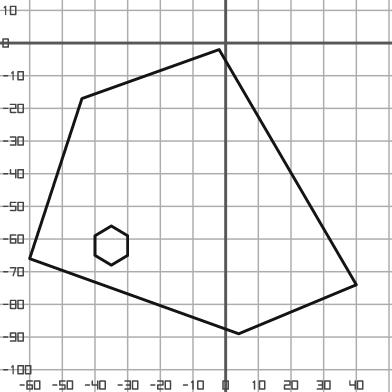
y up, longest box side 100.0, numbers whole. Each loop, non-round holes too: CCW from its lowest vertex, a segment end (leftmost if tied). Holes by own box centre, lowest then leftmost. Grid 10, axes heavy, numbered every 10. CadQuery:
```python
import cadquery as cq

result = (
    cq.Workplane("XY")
    .moveTo(4.0, -89.0)
    .lineTo(40.0, -74.0)
    .lineTo(-2.0, -2.0)
    .lineTo(-44.0, -17.0)
    .lineTo(-60.0, -66.0)
    .close()
    .moveTo(-35.0, -68.0)
    .lineTo(-30.0, -65.0)
    .lineTo(-30.0, -59.0)
    .lineTo(-35.0, -56.0)
    .lineTo(-40.0, -59.0)
    .lineTo(-40.0, -65.0)
    .close()
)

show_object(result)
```